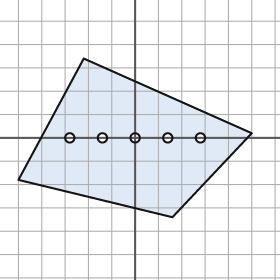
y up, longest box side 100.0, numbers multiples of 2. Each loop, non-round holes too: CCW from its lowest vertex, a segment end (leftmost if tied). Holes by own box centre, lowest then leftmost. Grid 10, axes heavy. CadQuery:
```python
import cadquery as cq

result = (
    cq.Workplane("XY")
    .moveTo(16.0, -34.0)
    .lineTo(50.0, 2.0)
    .lineTo(-22.0, 34.0)
    .lineTo(-50.0, -18.0)
    .close()
    .moveTo(-28.0, 0.0)
    .circle(2.0)
    .moveTo(-14.0, 0.0)
    .circle(2.0)
    .moveTo(0.0, 0.0)
    .circle(2.0)
    .moveTo(14.0, 0.0)
    .circle(2.0)
    .moveTo(28.0, 0.0)
    .circle(2.0)
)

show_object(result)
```